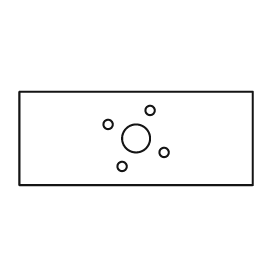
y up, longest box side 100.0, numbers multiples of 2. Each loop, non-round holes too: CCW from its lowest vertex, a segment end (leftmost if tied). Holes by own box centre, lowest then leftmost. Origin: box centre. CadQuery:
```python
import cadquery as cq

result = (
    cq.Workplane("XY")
    .moveTo(-50.0, -20.0)
    .lineTo(50.0, -20.0)
    .lineTo(50.0, 20.0)
    .lineTo(-50.0, 20.0)
    .close()
    .moveTo(-6.0, -12.0)
    .circle(2.0)
    .moveTo(12.0, -6.0)
    .circle(2.0)
    .moveTo(0.0, 0.0)
    .circle(6.0)
    .moveTo(-12.0, 6.0)
    .circle(2.0)
    .moveTo(6.0, 12.0)
    .circle(2.0)
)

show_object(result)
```